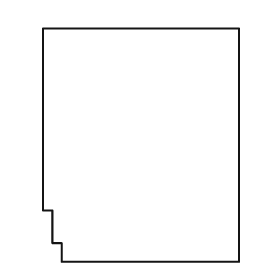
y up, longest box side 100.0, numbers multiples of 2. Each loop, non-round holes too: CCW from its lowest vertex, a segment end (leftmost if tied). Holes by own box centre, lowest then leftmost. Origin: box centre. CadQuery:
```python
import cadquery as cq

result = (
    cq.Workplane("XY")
    .moveTo(-34.0, -50.0)
    .lineTo(42.0, -50.0)
    .lineTo(42.0, 50.0)
    .lineTo(-42.0, 50.0)
    .lineTo(-42.0, -28.0)
    .lineTo(-38.0, -28.0)
    .lineTo(-38.0, -42.0)
    .lineTo(-34.0, -42.0)
    .close()
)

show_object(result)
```